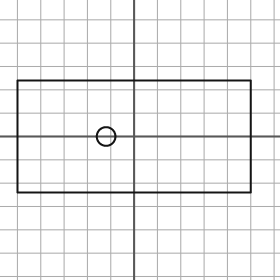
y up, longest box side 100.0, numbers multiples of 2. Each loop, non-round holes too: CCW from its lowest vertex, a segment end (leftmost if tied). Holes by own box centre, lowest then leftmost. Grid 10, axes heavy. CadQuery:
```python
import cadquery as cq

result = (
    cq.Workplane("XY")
    .moveTo(-50.0, -24.0)
    .lineTo(50.0, -24.0)
    .lineTo(50.0, 24.0)
    .lineTo(-50.0, 24.0)
    .close()
    .moveTo(-12.0, 0.0)
    .circle(4.0)
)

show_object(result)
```